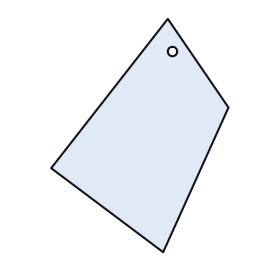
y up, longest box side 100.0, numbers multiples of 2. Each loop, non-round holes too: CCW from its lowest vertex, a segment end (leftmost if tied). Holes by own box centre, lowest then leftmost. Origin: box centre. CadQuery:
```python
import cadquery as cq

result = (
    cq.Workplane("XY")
    .moveTo(10.0, -50.0)
    .lineTo(38.0, 12.0)
    .lineTo(12.0, 50.0)
    .lineTo(-38.0, -14.0)
    .close()
    .moveTo(14.0, 36.0)
    .circle(2.0)
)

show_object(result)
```